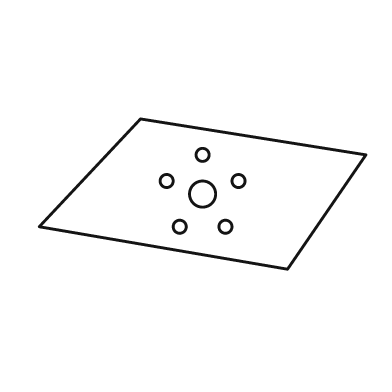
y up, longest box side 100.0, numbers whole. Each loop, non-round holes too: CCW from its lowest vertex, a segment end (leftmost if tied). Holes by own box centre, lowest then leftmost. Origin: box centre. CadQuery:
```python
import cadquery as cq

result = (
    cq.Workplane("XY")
    .moveTo(26.0, -23.0)
    .lineTo(50.0, 12.0)
    .lineTo(-19.0, 23.0)
    .lineTo(-50.0, -10.0)
    .close()
    .moveTo(-7.0, -10.0)
    .circle(2.0)
    .moveTo(7.0, -10.0)
    .circle(2.0)
    .moveTo(0.0, 0.0)
    .circle(4.0)
    .moveTo(-11.0, 4.0)
    .circle(2.0)
    .moveTo(11.0, 4.0)
    .circle(2.0)
    .moveTo(0.0, 12.0)
    .circle(2.0)
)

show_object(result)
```